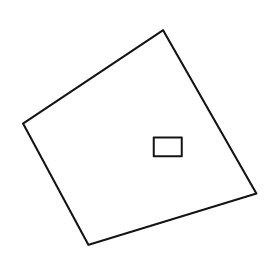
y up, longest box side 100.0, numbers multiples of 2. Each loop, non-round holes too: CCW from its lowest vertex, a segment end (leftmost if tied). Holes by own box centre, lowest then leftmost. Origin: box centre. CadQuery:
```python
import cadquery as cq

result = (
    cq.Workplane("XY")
    .moveTo(-22.0, -46.0)
    .lineTo(50.0, -24.0)
    .lineTo(10.0, 46.0)
    .lineTo(-50.0, 6.0)
    .close()
    .moveTo(6.0, -8.0)
    .lineTo(18.0, -8.0)
    .lineTo(18.0, 0.0)
    .lineTo(6.0, 0.0)
    .close()
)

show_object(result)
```